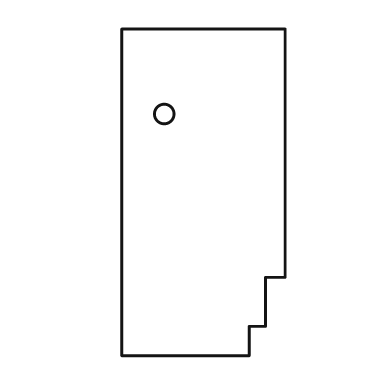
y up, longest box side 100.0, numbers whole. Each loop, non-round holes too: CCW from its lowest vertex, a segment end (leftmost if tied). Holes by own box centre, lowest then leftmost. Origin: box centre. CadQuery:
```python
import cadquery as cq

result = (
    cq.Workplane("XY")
    .moveTo(-25.0, -50.0)
    .lineTo(14.0, -50.0)
    .lineTo(14.0, -41.0)
    .lineTo(19.0, -41.0)
    .lineTo(19.0, -26.0)
    .lineTo(25.0, -26.0)
    .lineTo(25.0, 50.0)
    .lineTo(-25.0, 50.0)
    .close()
    .moveTo(-12.0, 24.0)
    .circle(3.0)
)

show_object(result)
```